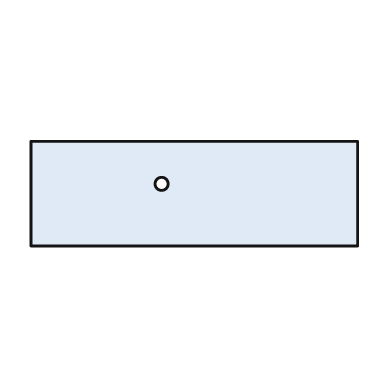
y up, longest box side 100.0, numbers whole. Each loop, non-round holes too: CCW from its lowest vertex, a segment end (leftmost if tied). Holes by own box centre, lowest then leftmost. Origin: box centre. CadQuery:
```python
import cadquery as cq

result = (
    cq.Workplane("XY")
    .moveTo(-50.0, -16.0)
    .lineTo(50.0, -16.0)
    .lineTo(50.0, 16.0)
    .lineTo(-50.0, 16.0)
    .close()
    .moveTo(-10.0, 3.0)
    .circle(2.0)
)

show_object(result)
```